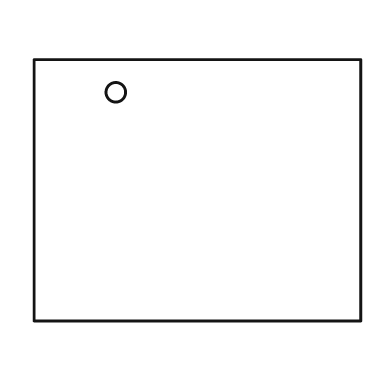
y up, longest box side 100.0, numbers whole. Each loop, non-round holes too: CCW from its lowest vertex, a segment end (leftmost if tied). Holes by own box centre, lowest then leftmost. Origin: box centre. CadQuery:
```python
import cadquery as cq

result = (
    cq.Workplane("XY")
    .moveTo(-50.0, -40.0)
    .lineTo(50.0, -40.0)
    .lineTo(50.0, 40.0)
    .lineTo(-50.0, 40.0)
    .close()
    .moveTo(-25.0, 30.0)
    .circle(3.0)
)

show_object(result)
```